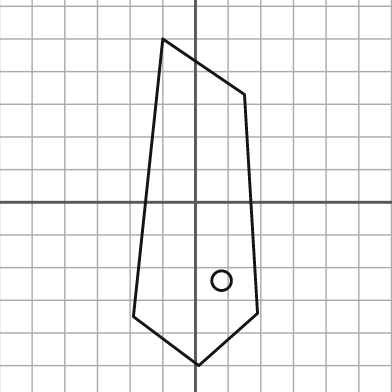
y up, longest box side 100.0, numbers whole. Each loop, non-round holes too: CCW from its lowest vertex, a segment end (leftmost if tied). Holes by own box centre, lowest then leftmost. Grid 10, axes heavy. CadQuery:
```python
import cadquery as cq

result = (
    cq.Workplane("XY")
    .moveTo(1.0, -50.0)
    .lineTo(19.0, -34.0)
    .lineTo(15.0, 33.0)
    .lineTo(-10.0, 50.0)
    .lineTo(-19.0, -35.0)
    .close()
    .moveTo(8.0, -24.0)
    .circle(3.0)
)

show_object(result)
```